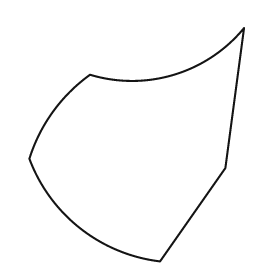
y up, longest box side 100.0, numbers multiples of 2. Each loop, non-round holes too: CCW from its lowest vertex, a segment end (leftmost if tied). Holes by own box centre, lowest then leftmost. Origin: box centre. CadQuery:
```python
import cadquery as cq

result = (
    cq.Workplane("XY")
    .moveTo(10.0, -50.0)
    .lineTo(38.0, -10.0)
    .lineTo(46.0, 50.0)
    .threePointArc((16.0, 30.0), (-20.0, 30.0))
    .threePointArc((-36.0, 14.0), (-46.0, -6.0))
    .threePointArc((-24.0, -36.0), (10.0, -50.0))
    .close()
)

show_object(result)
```